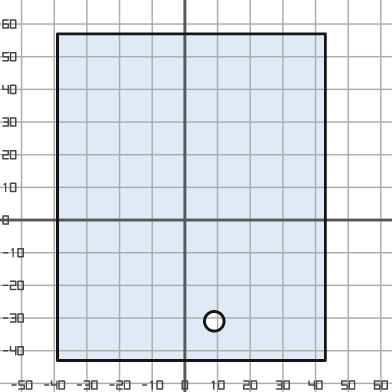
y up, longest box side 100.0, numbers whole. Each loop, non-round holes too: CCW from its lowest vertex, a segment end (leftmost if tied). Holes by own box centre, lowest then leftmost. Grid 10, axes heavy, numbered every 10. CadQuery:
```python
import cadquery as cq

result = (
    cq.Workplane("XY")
    .moveTo(-39.0, -43.0)
    .lineTo(43.0, -43.0)
    .lineTo(43.0, 57.0)
    .lineTo(-39.0, 57.0)
    .close()
    .moveTo(9.0, -31.0)
    .circle(3.0)
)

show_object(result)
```